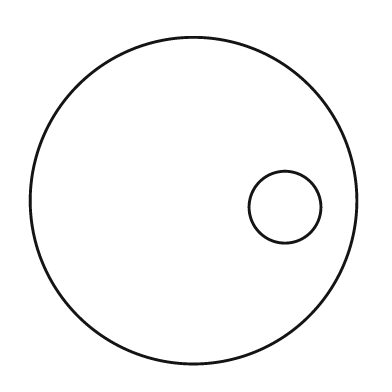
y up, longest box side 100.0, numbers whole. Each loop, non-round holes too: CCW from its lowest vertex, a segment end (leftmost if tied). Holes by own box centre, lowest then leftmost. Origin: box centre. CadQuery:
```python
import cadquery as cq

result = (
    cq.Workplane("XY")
    .moveTo(0.0, 0.0)
    .circle(50.0)
    .moveTo(28.0, -2.0)
    .circle(11.0)
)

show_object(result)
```